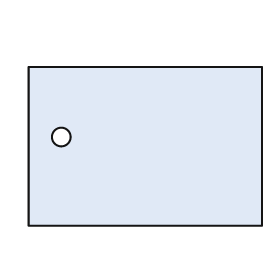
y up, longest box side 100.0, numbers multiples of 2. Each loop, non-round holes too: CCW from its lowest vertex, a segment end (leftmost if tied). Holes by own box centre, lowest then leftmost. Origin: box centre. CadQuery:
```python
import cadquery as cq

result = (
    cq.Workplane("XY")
    .moveTo(-50.0, -34.0)
    .lineTo(50.0, -34.0)
    .lineTo(50.0, 34.0)
    .lineTo(-50.0, 34.0)
    .close()
    .moveTo(-36.0, 4.0)
    .circle(4.0)
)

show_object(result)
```